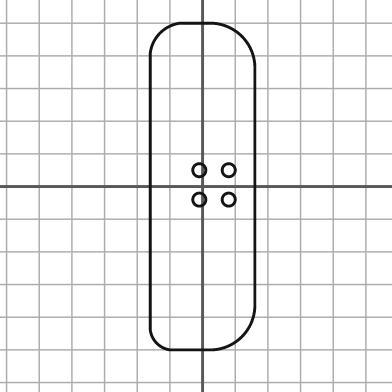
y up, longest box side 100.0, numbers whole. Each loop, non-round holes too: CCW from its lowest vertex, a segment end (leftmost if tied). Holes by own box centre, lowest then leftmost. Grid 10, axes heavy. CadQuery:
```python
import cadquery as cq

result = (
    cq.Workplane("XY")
    .moveTo(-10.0, -50.0)
    .lineTo(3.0, -50.0)
    .threePointArc((12.0, -46.0), (16.0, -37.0))
    .lineTo(16.0, 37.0)
    .threePointArc((12.0, 46.0), (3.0, 50.0))
    .lineTo(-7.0, 50.0)
    .threePointArc((-13.0, 47.0), (-16.0, 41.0))
    .lineTo(-16.0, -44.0)
    .threePointArc((-14.0, -48.0), (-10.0, -50.0))
    .close()
    .moveTo(-1.0, -4.0)
    .circle(2.0)
    .moveTo(8.0, -4.0)
    .circle(2.0)
    .moveTo(-1.0, 5.0)
    .circle(2.0)
    .moveTo(8.0, 5.0)
    .circle(2.0)
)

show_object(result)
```